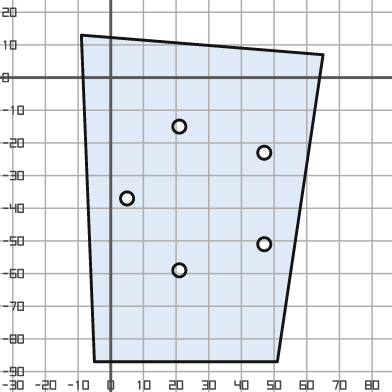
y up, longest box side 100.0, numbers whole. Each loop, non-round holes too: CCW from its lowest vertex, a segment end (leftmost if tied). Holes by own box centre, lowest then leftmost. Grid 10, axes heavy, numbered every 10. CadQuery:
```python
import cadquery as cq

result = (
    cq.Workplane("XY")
    .moveTo(-5.0, -87.0)
    .lineTo(51.0, -87.0)
    .lineTo(65.0, 7.0)
    .lineTo(-9.0, 13.0)
    .close()
    .moveTo(21.0, -59.0)
    .circle(2.0)
    .moveTo(47.0, -51.0)
    .circle(2.0)
    .moveTo(5.0, -37.0)
    .circle(2.0)
    .moveTo(47.0, -23.0)
    .circle(2.0)
    .moveTo(21.0, -15.0)
    .circle(2.0)
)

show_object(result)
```